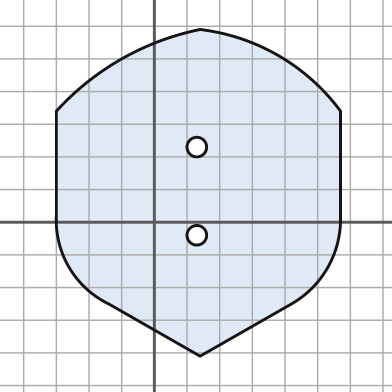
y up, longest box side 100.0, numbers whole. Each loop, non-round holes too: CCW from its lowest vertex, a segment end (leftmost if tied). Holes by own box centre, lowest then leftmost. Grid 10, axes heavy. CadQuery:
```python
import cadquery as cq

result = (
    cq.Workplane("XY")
    .moveTo(14.0, -41.0)
    .lineTo(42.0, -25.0)
    .threePointArc((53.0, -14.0), (57.0, 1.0))
    .lineTo(57.0, 34.0)
    .threePointArc((38.0, 51.0), (14.0, 59.0))
    .threePointArc((-10.0, 50.0), (-30.0, 34.0))
    .lineTo(-30.0, 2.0)
    .threePointArc((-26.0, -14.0), (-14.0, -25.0))
    .close()
    .moveTo(13.0, -4.0)
    .circle(3.0)
    .moveTo(13.0, 23.0)
    .circle(3.0)
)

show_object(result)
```